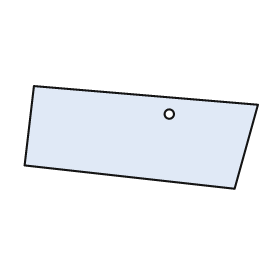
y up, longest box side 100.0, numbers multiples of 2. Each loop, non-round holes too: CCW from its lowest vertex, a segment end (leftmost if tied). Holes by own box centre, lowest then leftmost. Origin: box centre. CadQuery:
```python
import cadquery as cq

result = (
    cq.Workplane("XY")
    .moveTo(40.0, -22.0)
    .lineTo(50.0, 14.0)
    .lineTo(-46.0, 22.0)
    .lineTo(-50.0, -12.0)
    .close()
    .moveTo(12.0, 10.0)
    .circle(2.0)
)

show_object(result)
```